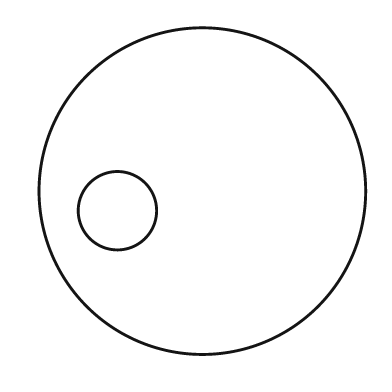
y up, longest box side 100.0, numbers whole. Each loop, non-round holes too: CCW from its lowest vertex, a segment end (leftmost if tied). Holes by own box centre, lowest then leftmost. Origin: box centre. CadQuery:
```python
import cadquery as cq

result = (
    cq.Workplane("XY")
    .moveTo(0.0, 0.0)
    .circle(50.0)
    .moveTo(-26.0, -6.0)
    .circle(12.0)
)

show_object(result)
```